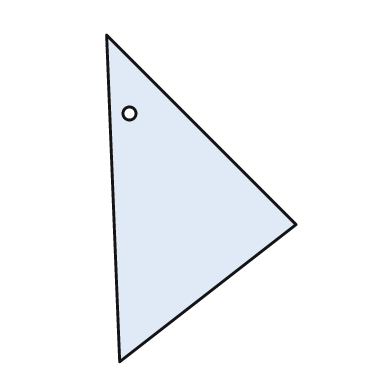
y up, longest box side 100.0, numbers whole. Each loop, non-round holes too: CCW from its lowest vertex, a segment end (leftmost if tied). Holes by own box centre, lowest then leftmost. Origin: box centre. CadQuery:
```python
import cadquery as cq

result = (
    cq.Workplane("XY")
    .moveTo(-25.0, -50.0)
    .lineTo(29.0, -8.0)
    .lineTo(-29.0, 50.0)
    .close()
    .moveTo(-22.0, 26.0)
    .circle(2.0)
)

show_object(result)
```